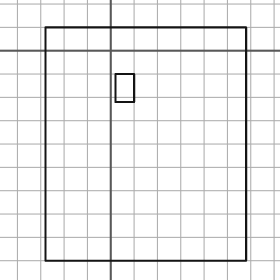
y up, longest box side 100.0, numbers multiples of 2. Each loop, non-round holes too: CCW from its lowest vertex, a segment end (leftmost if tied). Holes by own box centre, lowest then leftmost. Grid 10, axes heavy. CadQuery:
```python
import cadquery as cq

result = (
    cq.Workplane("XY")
    .moveTo(-28.0, -90.0)
    .lineTo(58.0, -90.0)
    .lineTo(58.0, 10.0)
    .lineTo(-28.0, 10.0)
    .close()
    .moveTo(2.0, -22.0)
    .lineTo(10.0, -22.0)
    .lineTo(10.0, -10.0)
    .lineTo(2.0, -10.0)
    .close()
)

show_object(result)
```